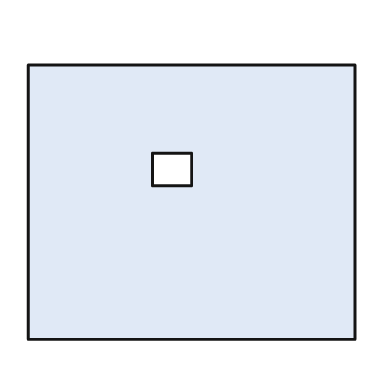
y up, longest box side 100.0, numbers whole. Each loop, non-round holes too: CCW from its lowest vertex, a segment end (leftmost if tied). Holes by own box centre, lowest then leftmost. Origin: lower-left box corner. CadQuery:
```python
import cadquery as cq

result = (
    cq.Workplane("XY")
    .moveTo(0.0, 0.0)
    .lineTo(100.0, 0.0)
    .lineTo(100.0, 84.0)
    .lineTo(0.0, 84.0)
    .close()
    .moveTo(38.0, 47.0)
    .lineTo(50.0, 47.0)
    .lineTo(50.0, 57.0)
    .lineTo(38.0, 57.0)
    .close()
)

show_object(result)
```